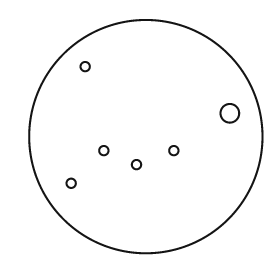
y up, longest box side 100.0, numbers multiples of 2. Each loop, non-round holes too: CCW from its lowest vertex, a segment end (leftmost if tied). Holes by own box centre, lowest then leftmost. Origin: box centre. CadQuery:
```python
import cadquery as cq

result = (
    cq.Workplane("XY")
    .moveTo(0.0, 0.0)
    .circle(50.0)
    .moveTo(-32.0, -20.0)
    .circle(2.0)
    .moveTo(-4.0, -12.0)
    .circle(2.0)
    .moveTo(-18.0, -6.0)
    .circle(2.0)
    .moveTo(12.0, -6.0)
    .circle(2.0)
    .moveTo(36.0, 10.0)
    .circle(4.0)
    .moveTo(-26.0, 30.0)
    .circle(2.0)
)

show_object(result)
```